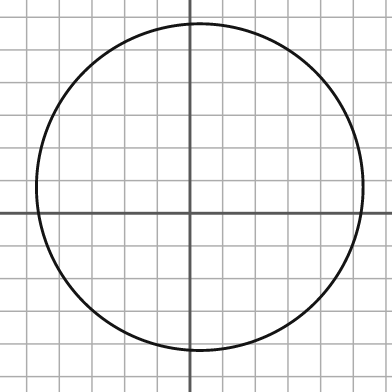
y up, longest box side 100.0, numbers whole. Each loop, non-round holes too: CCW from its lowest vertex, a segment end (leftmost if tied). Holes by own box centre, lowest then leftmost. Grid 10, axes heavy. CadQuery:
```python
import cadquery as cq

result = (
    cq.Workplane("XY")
    .moveTo(3.0, 8.0)
    .circle(50.0)
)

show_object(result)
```